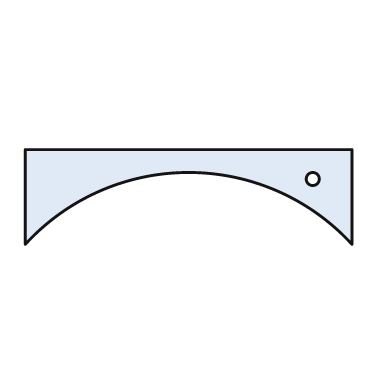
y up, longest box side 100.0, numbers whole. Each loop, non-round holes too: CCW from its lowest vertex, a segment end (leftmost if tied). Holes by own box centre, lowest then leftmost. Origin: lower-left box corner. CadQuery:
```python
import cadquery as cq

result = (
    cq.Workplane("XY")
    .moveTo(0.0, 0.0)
    .threePointArc((50.0, 22.0), (100.0, 0.0))
    .lineTo(100.0, 29.0)
    .lineTo(0.0, 29.0)
    .close()
    .moveTo(88.0, 20.0)
    .circle(2.0)
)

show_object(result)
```